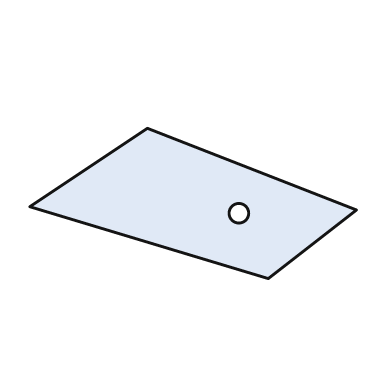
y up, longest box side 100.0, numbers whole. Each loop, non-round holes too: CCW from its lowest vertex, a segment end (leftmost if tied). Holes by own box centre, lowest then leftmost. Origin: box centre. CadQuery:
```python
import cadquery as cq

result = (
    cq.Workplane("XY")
    .moveTo(23.0, -23.0)
    .lineTo(50.0, -2.0)
    .lineTo(-14.0, 23.0)
    .lineTo(-50.0, -1.0)
    .close()
    .moveTo(14.0, -3.0)
    .circle(3.0)
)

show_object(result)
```